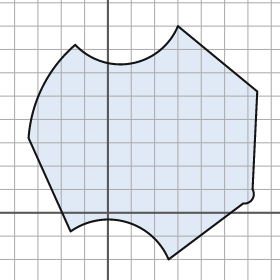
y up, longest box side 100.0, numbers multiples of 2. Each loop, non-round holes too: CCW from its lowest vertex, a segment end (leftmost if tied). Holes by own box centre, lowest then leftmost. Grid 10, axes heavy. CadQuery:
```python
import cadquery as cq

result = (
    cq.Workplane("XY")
    .moveTo(26.0, -20.0)
    .lineTo(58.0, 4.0)
    .threePointArc((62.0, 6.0), (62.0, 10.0))
    .lineTo(64.0, 52.0)
    .lineTo(30.0, 80.0)
    .threePointArc((10.0, 64.0), (-14.0, 72.0))
    .threePointArc((-28.0, 54.0), (-34.0, 32.0))
    .lineTo(-16.0, -8.0)
    .threePointArc((8.0, -4.0), (26.0, -20.0))
    .close()
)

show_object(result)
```